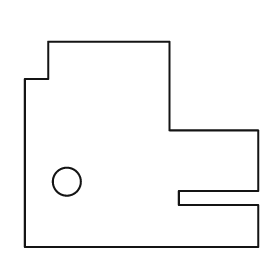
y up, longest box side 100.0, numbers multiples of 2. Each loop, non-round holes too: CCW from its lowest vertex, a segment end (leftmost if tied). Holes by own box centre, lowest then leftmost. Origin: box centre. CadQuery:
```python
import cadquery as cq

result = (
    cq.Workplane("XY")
    .moveTo(-50.0, -44.0)
    .lineTo(50.0, -44.0)
    .lineTo(50.0, -26.0)
    .lineTo(16.0, -26.0)
    .lineTo(16.0, -20.0)
    .lineTo(50.0, -20.0)
    .lineTo(50.0, 6.0)
    .lineTo(12.0, 6.0)
    .lineTo(12.0, 44.0)
    .lineTo(-40.0, 44.0)
    .lineTo(-40.0, 28.0)
    .lineTo(-50.0, 28.0)
    .close()
    .moveTo(-32.0, -16.0)
    .circle(6.0)
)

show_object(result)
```